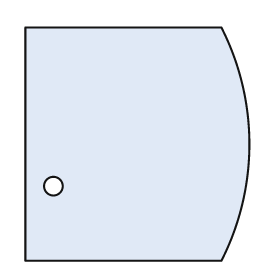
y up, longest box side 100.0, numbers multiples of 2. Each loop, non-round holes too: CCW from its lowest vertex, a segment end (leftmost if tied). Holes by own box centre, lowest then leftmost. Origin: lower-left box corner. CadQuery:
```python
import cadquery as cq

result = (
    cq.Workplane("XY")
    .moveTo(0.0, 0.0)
    .lineTo(84.0, 0.0)
    .threePointArc((96.0, 50.0), (84.0, 100.0))
    .lineTo(0.0, 100.0)
    .close()
    .moveTo(12.0, 32.0)
    .circle(4.0)
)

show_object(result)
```